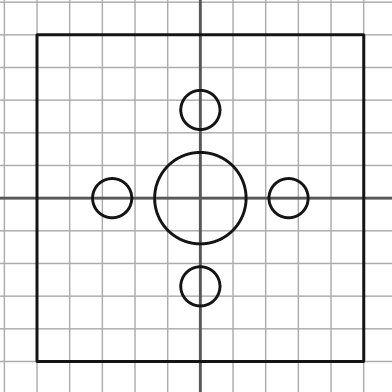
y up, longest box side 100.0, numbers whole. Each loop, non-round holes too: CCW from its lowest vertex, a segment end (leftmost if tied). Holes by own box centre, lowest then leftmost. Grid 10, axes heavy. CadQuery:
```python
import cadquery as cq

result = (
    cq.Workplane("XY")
    .moveTo(-50.0, -50.0)
    .lineTo(50.0, -50.0)
    .lineTo(50.0, 50.0)
    .lineTo(-50.0, 50.0)
    .close()
    .moveTo(0.0, -27.0)
    .circle(6.0)
    .moveTo(-27.0, 0.0)
    .circle(6.0)
    .moveTo(0.0, 0.0)
    .circle(14.0)
    .moveTo(27.0, 0.0)
    .circle(6.0)
    .moveTo(0.0, 27.0)
    .circle(6.0)
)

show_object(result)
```